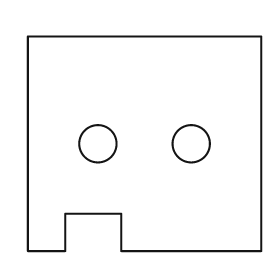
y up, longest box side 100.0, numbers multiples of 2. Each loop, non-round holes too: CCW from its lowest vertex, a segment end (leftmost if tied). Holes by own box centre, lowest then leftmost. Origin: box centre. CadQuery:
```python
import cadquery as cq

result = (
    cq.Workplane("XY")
    .moveTo(-50.0, -46.0)
    .lineTo(-34.0, -46.0)
    .lineTo(-34.0, -30.0)
    .lineTo(-10.0, -30.0)
    .lineTo(-10.0, -46.0)
    .lineTo(50.0, -46.0)
    .lineTo(50.0, 46.0)
    .lineTo(-50.0, 46.0)
    .close()
    .moveTo(-20.0, 0.0)
    .circle(8.0)
    .moveTo(20.0, 0.0)
    .circle(8.0)
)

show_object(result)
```